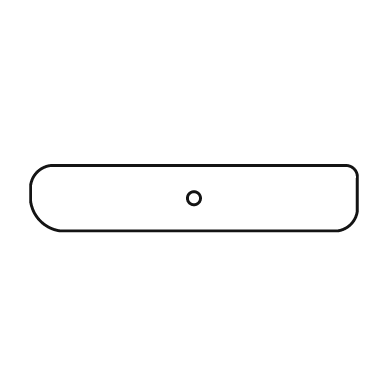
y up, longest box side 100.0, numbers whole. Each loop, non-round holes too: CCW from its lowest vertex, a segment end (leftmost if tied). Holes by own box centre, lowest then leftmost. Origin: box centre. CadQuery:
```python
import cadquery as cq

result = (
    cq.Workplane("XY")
    .moveTo(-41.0, -10.0)
    .lineTo(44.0, -10.0)
    .threePointArc((48.0, -8.0), (50.0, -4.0))
    .lineTo(50.0, 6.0)
    .threePointArc((49.0, 9.0), (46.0, 10.0))
    .lineTo(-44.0, 10.0)
    .threePointArc((-48.0, 8.0), (-50.0, 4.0))
    .lineTo(-50.0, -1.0)
    .threePointArc((-47.0, -7.0), (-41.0, -10.0))
    .close()
    .moveTo(0.0, 0.0)
    .circle(2.0)
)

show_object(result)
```